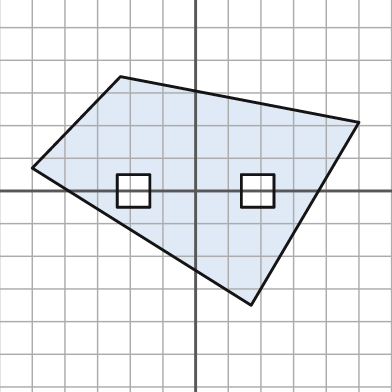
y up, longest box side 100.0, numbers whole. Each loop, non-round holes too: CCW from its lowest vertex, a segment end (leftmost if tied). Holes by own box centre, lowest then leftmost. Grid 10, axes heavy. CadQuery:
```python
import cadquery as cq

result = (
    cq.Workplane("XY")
    .moveTo(17.0, -35.0)
    .lineTo(50.0, 21.0)
    .lineTo(-23.0, 35.0)
    .lineTo(-50.0, 7.0)
    .close()
    .moveTo(-24.0, -5.0)
    .lineTo(-14.0, -5.0)
    .lineTo(-14.0, 5.0)
    .lineTo(-24.0, 5.0)
    .close()
    .moveTo(14.0, -5.0)
    .lineTo(24.0, -5.0)
    .lineTo(24.0, 5.0)
    .lineTo(14.0, 5.0)
    .close()
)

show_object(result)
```